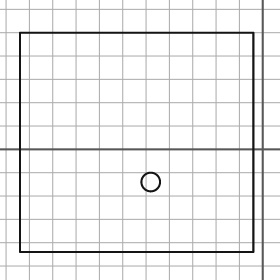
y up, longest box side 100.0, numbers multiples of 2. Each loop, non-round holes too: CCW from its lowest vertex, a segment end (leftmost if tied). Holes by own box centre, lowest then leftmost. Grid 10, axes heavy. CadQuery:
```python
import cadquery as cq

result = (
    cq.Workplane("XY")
    .moveTo(-104.0, -44.0)
    .lineTo(-4.0, -44.0)
    .lineTo(-4.0, 50.0)
    .lineTo(-104.0, 50.0)
    .close()
    .moveTo(-48.0, -14.0)
    .circle(4.0)
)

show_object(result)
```